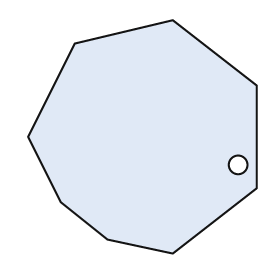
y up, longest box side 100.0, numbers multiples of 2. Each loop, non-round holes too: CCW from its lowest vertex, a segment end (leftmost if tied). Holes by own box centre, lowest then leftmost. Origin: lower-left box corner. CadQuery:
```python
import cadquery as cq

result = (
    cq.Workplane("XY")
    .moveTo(62.0, 0.0)
    .lineTo(98.0, 28.0)
    .lineTo(98.0, 72.0)
    .lineTo(62.0, 100.0)
    .lineTo(20.0, 90.0)
    .lineTo(0.0, 50.0)
    .lineTo(14.0, 22.0)
    .lineTo(34.0, 6.0)
    .close()
    .moveTo(90.0, 38.0)
    .circle(4.0)
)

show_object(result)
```